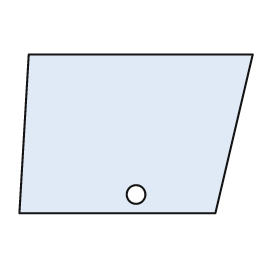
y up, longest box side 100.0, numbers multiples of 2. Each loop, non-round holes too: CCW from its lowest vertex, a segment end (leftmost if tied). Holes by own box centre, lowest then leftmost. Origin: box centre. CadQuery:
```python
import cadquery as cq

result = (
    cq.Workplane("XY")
    .moveTo(-50.0, -34.0)
    .lineTo(34.0, -34.0)
    .lineTo(50.0, 34.0)
    .lineTo(-46.0, 34.0)
    .close()
    .moveTo(0.0, -26.0)
    .circle(4.0)
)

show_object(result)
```